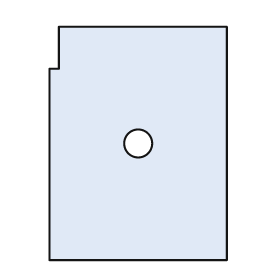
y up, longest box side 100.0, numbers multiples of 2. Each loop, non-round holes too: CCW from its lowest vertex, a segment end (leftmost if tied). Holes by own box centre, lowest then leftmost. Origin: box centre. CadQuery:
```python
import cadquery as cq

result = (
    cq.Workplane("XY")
    .moveTo(-38.0, -50.0)
    .lineTo(38.0, -50.0)
    .lineTo(38.0, 50.0)
    .lineTo(-34.0, 50.0)
    .lineTo(-34.0, 32.0)
    .lineTo(-38.0, 32.0)
    .close()
    .moveTo(0.0, 0.0)
    .circle(6.0)
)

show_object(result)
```